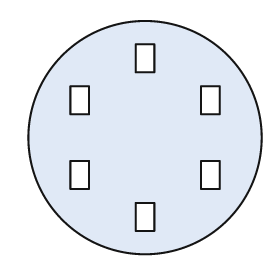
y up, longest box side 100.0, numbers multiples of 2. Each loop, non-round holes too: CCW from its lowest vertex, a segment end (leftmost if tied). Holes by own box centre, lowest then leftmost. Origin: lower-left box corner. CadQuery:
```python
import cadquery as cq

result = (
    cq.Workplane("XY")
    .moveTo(50.0, 50.0)
    .circle(50.0)
    .moveTo(46.0, 10.0)
    .lineTo(54.0, 10.0)
    .lineTo(54.0, 22.0)
    .lineTo(46.0, 22.0)
    .close()
    .moveTo(18.0, 28.0)
    .lineTo(26.0, 28.0)
    .lineTo(26.0, 40.0)
    .lineTo(18.0, 40.0)
    .close()
    .moveTo(74.0, 28.0)
    .lineTo(82.0, 28.0)
    .lineTo(82.0, 40.0)
    .lineTo(74.0, 40.0)
    .close()
    .moveTo(18.0, 60.0)
    .lineTo(26.0, 60.0)
    .lineTo(26.0, 72.0)
    .lineTo(18.0, 72.0)
    .close()
    .moveTo(74.0, 60.0)
    .lineTo(82.0, 60.0)
    .lineTo(82.0, 72.0)
    .lineTo(74.0, 72.0)
    .close()
    .moveTo(46.0, 78.0)
    .lineTo(54.0, 78.0)
    .lineTo(54.0, 90.0)
    .lineTo(46.0, 90.0)
    .close()
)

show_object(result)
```